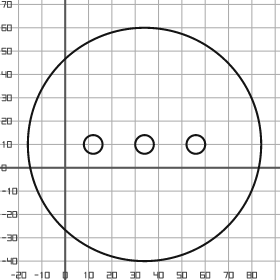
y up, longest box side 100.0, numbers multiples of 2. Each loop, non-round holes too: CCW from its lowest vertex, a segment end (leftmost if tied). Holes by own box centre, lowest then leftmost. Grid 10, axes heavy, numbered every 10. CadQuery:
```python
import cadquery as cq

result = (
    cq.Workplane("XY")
    .moveTo(34.0, 10.0)
    .circle(50.0)
    .moveTo(12.0, 10.0)
    .circle(4.0)
    .moveTo(34.0, 10.0)
    .circle(4.0)
    .moveTo(56.0, 10.0)
    .circle(4.0)
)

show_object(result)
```